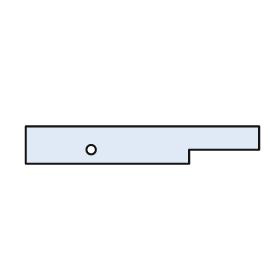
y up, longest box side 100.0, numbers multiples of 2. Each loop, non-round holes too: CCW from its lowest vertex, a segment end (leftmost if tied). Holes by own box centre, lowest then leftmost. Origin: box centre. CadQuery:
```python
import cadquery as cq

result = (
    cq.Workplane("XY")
    .moveTo(-50.0, -8.0)
    .lineTo(20.0, -8.0)
    .lineTo(20.0, -2.0)
    .lineTo(50.0, -2.0)
    .lineTo(50.0, 8.0)
    .lineTo(-50.0, 8.0)
    .close()
    .moveTo(-22.0, -2.0)
    .circle(2.0)
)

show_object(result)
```